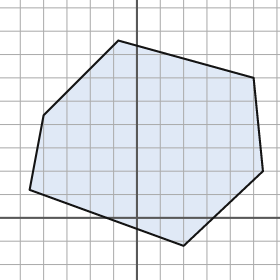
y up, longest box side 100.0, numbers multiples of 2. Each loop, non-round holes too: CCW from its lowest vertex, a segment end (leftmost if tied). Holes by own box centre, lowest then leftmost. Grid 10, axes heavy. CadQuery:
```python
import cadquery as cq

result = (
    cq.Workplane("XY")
    .moveTo(20.0, -12.0)
    .lineTo(54.0, 20.0)
    .lineTo(50.0, 60.0)
    .lineTo(-8.0, 76.0)
    .lineTo(-40.0, 44.0)
    .lineTo(-46.0, 12.0)
    .close()
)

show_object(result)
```